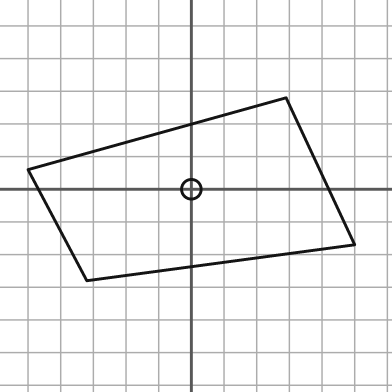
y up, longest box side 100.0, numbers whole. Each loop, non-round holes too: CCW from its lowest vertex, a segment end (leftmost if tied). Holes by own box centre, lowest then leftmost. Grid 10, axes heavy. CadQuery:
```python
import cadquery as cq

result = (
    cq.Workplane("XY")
    .moveTo(-32.0, -28.0)
    .lineTo(50.0, -17.0)
    .lineTo(29.0, 28.0)
    .lineTo(-50.0, 6.0)
    .close()
    .moveTo(0.0, 0.0)
    .circle(3.0)
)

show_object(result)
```